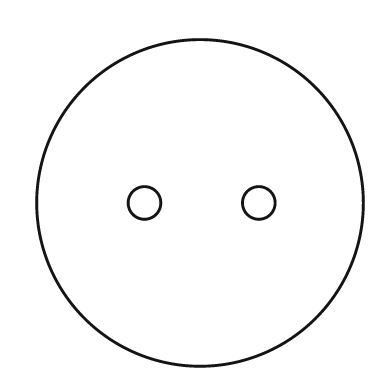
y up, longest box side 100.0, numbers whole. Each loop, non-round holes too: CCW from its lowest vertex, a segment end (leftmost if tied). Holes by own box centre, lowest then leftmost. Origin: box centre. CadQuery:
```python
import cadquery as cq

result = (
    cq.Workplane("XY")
    .moveTo(0.0, 0.0)
    .circle(50.0)
    .moveTo(-17.0, 0.0)
    .circle(5.0)
    .moveTo(18.0, 0.0)
    .circle(5.0)
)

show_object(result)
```